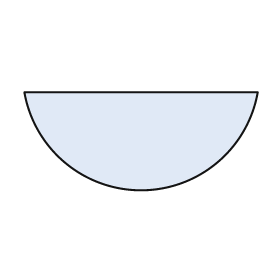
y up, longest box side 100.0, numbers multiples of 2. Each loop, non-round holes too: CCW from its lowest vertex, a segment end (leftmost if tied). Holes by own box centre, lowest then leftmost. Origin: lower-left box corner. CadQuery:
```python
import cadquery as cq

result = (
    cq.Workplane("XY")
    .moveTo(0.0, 42.0)
    .threePointArc((50.0, 0.0), (100.0, 42.0))
    .close()
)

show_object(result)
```